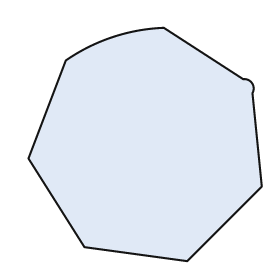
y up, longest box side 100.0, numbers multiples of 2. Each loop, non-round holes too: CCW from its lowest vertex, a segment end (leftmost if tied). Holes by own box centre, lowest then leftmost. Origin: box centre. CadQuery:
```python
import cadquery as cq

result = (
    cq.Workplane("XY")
    .moveTo(18.0, -50.0)
    .lineTo(50.0, -18.0)
    .lineTo(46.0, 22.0)
    .threePointArc((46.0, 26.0), (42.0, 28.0))
    .lineTo(8.0, 50.0)
    .threePointArc((-14.0, 46.0), (-34.0, 36.0))
    .lineTo(-50.0, -6.0)
    .lineTo(-26.0, -44.0)
    .close()
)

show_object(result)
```